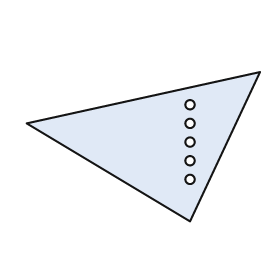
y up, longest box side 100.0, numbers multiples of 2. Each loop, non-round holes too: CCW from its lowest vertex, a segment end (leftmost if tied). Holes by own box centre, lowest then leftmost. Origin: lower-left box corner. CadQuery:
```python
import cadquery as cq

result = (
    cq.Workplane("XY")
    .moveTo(70.0, 0.0)
    .lineTo(100.0, 64.0)
    .lineTo(0.0, 42.0)
    .close()
    .moveTo(70.0, 18.0)
    .circle(2.0)
    .moveTo(70.0, 26.0)
    .circle(2.0)
    .moveTo(70.0, 34.0)
    .circle(2.0)
    .moveTo(70.0, 42.0)
    .circle(2.0)
    .moveTo(70.0, 50.0)
    .circle(2.0)
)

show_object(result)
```